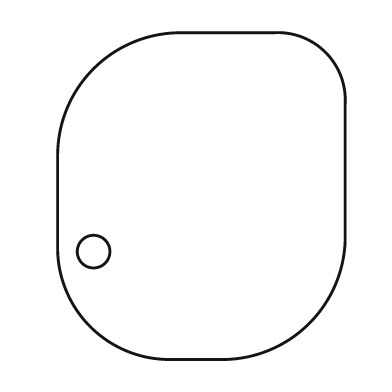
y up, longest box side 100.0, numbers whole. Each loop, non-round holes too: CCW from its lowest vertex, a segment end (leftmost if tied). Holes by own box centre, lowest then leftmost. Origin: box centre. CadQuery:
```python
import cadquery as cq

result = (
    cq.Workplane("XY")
    .moveTo(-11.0, -50.0)
    .lineTo(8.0, -50.0)
    .threePointArc((33.0, -39.0), (44.0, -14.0))
    .lineTo(44.0, 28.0)
    .threePointArc((38.0, 44.0), (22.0, 50.0))
    .lineTo(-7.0, 50.0)
    .threePointArc((-33.0, 39.0), (-44.0, 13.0))
    .lineTo(-44.0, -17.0)
    .threePointArc((-34.0, -40.0), (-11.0, -50.0))
    .close()
    .moveTo(-33.0, -17.0)
    .circle(5.0)
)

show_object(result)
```